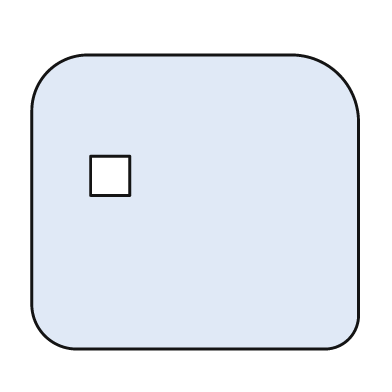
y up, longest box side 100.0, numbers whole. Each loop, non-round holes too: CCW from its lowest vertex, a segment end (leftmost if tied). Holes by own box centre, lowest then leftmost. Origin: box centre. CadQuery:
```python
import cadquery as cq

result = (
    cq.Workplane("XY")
    .moveTo(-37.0, -45.0)
    .lineTo(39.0, -45.0)
    .threePointArc((47.0, -42.0), (50.0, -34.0))
    .lineTo(50.0, 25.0)
    .threePointArc((44.0, 39.0), (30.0, 45.0))
    .lineTo(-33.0, 45.0)
    .threePointArc((-45.0, 40.0), (-50.0, 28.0))
    .lineTo(-50.0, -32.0)
    .threePointArc((-46.0, -41.0), (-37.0, -45.0))
    .close()
    .moveTo(-32.0, 2.0)
    .lineTo(-20.0, 2.0)
    .lineTo(-20.0, 14.0)
    .lineTo(-32.0, 14.0)
    .close()
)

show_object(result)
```